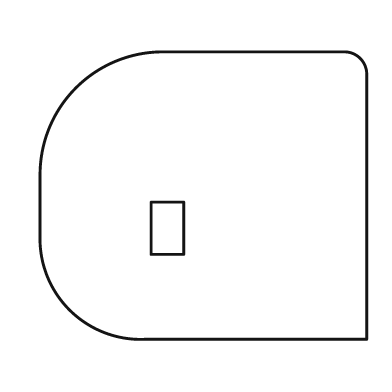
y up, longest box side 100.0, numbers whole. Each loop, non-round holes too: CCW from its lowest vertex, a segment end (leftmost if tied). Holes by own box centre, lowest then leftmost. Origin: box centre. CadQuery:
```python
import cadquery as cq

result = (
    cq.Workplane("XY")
    .moveTo(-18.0, -44.0)
    .lineTo(50.0, -44.0)
    .lineTo(50.0, 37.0)
    .threePointArc((48.0, 42.0), (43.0, 44.0))
    .lineTo(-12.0, 44.0)
    .threePointArc((-39.0, 33.0), (-50.0, 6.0))
    .lineTo(-50.0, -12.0)
    .threePointArc((-41.0, -35.0), (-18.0, -44.0))
    .close()
    .moveTo(-16.0, -18.0)
    .lineTo(-6.0, -18.0)
    .lineTo(-6.0, -2.0)
    .lineTo(-16.0, -2.0)
    .close()
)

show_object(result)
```